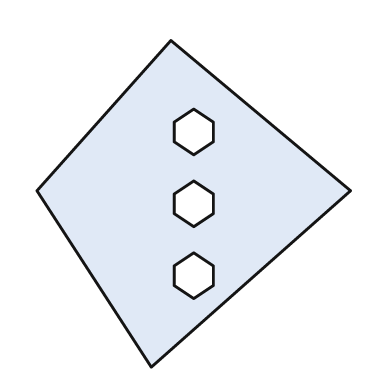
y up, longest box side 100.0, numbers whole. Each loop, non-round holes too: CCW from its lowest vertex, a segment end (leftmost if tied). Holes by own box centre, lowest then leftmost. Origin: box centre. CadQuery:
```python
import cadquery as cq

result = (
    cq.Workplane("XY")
    .moveTo(-13.0, -50.0)
    .lineTo(48.0, 4.0)
    .lineTo(-7.0, 50.0)
    .lineTo(-48.0, 4.0)
    .close()
    .moveTo(0.0, -29.0)
    .lineTo(6.0, -25.0)
    .lineTo(6.0, -19.0)
    .lineTo(0.0, -15.0)
    .lineTo(-6.0, -19.0)
    .lineTo(-6.0, -25.0)
    .close()
    .moveTo(0.0, -7.0)
    .lineTo(6.0, -3.0)
    .lineTo(6.0, 3.0)
    .lineTo(0.0, 7.0)
    .lineTo(-6.0, 3.0)
    .lineTo(-6.0, -3.0)
    .close()
    .moveTo(0.0, 15.0)
    .lineTo(6.0, 19.0)
    .lineTo(6.0, 25.0)
    .lineTo(0.0, 29.0)
    .lineTo(-6.0, 25.0)
    .lineTo(-6.0, 19.0)
    .close()
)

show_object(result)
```